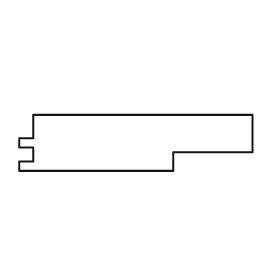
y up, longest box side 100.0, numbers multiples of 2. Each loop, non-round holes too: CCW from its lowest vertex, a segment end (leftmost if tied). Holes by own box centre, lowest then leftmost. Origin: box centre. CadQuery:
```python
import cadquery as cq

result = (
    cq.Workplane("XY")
    .moveTo(-50.0, -12.0)
    .lineTo(16.0, -12.0)
    .lineTo(16.0, -4.0)
    .lineTo(50.0, -4.0)
    .lineTo(50.0, 12.0)
    .lineTo(-44.0, 12.0)
    .lineTo(-44.0, 2.0)
    .lineTo(-50.0, 2.0)
    .lineTo(-50.0, -2.0)
    .lineTo(-44.0, -2.0)
    .lineTo(-44.0, -8.0)
    .lineTo(-50.0, -8.0)
    .close()
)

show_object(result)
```